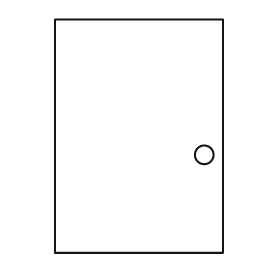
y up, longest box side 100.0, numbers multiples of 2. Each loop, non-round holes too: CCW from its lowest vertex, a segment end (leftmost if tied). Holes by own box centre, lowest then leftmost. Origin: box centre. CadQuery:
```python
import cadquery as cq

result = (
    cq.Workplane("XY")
    .moveTo(-36.0, -50.0)
    .lineTo(36.0, -50.0)
    .lineTo(36.0, 50.0)
    .lineTo(-36.0, 50.0)
    .close()
    .moveTo(28.0, -8.0)
    .circle(4.0)
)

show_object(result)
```